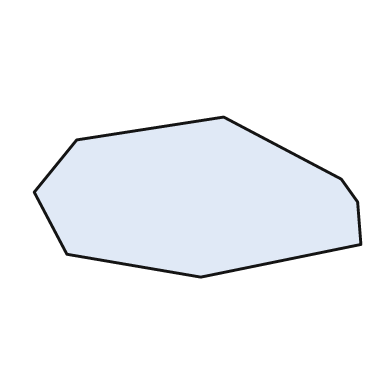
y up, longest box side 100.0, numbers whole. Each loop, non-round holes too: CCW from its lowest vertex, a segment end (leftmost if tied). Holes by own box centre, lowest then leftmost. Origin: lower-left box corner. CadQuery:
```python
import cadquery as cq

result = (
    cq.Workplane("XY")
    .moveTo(51.0, 0.0)
    .lineTo(100.0, 10.0)
    .lineTo(99.0, 23.0)
    .lineTo(94.0, 30.0)
    .lineTo(58.0, 49.0)
    .lineTo(13.0, 42.0)
    .lineTo(0.0, 26.0)
    .lineTo(10.0, 7.0)
    .close()
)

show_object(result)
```